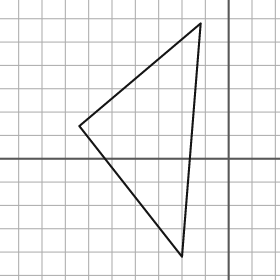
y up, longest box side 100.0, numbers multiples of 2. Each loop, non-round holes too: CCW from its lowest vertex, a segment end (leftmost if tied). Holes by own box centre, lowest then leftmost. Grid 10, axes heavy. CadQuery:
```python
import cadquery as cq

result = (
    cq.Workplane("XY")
    .moveTo(-20.0, -42.0)
    .lineTo(-12.0, 58.0)
    .lineTo(-64.0, 14.0)
    .close()
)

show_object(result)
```